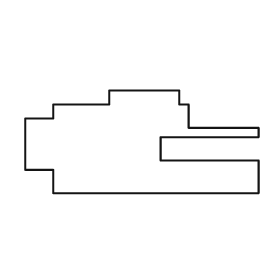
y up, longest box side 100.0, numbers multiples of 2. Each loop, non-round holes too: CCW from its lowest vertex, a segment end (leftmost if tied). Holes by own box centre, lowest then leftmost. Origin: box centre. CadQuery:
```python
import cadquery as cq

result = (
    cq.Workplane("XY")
    .moveTo(-38.0, -22.0)
    .lineTo(50.0, -22.0)
    .lineTo(50.0, -8.0)
    .lineTo(8.0, -8.0)
    .lineTo(8.0, 2.0)
    .lineTo(50.0, 2.0)
    .lineTo(50.0, 6.0)
    .lineTo(20.0, 6.0)
    .lineTo(20.0, 16.0)
    .lineTo(16.0, 16.0)
    .lineTo(16.0, 22.0)
    .lineTo(-14.0, 22.0)
    .lineTo(-14.0, 16.0)
    .lineTo(-38.0, 16.0)
    .lineTo(-38.0, 10.0)
    .lineTo(-50.0, 10.0)
    .lineTo(-50.0, -12.0)
    .lineTo(-38.0, -12.0)
    .close()
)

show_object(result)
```